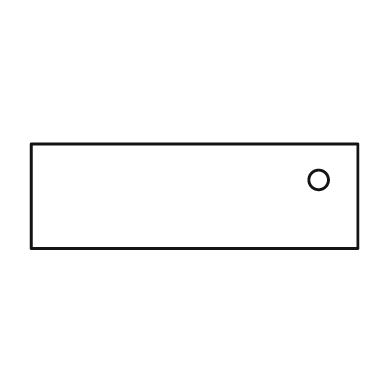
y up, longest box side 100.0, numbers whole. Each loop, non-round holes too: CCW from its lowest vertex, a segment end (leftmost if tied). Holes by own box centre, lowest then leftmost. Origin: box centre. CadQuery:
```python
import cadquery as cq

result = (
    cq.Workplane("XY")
    .moveTo(-50.0, -16.0)
    .lineTo(50.0, -16.0)
    .lineTo(50.0, 16.0)
    .lineTo(-50.0, 16.0)
    .close()
    .moveTo(38.0, 5.0)
    .circle(3.0)
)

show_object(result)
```